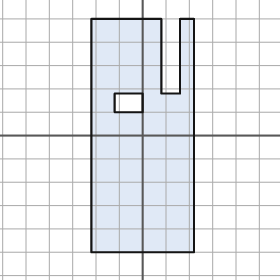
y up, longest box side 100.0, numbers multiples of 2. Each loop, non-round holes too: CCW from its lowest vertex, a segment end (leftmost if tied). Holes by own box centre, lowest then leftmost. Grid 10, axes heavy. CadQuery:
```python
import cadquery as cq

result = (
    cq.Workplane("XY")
    .moveTo(-22.0, -50.0)
    .lineTo(22.0, -50.0)
    .lineTo(22.0, 50.0)
    .lineTo(16.0, 50.0)
    .lineTo(16.0, 18.0)
    .lineTo(8.0, 18.0)
    .lineTo(8.0, 50.0)
    .lineTo(-22.0, 50.0)
    .close()
    .moveTo(-12.0, 10.0)
    .lineTo(0.0, 10.0)
    .lineTo(0.0, 18.0)
    .lineTo(-12.0, 18.0)
    .close()
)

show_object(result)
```